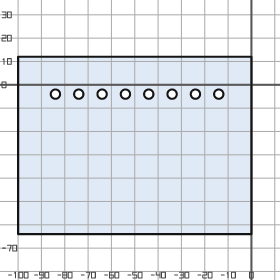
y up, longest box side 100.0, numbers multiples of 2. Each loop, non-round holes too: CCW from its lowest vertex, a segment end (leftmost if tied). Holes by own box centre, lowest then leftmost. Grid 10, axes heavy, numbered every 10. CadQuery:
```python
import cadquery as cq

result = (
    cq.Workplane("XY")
    .moveTo(-100.0, -64.0)
    .lineTo(0.0, -64.0)
    .lineTo(0.0, 12.0)
    .lineTo(-100.0, 12.0)
    .close()
    .moveTo(-84.0, -4.0)
    .circle(2.0)
    .moveTo(-74.0, -4.0)
    .circle(2.0)
    .moveTo(-64.0, -4.0)
    .circle(2.0)
    .moveTo(-54.0, -4.0)
    .circle(2.0)
    .moveTo(-44.0, -4.0)
    .circle(2.0)
    .moveTo(-34.0, -4.0)
    .circle(2.0)
    .moveTo(-24.0, -4.0)
    .circle(2.0)
    .moveTo(-14.0, -4.0)
    .circle(2.0)
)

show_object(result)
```